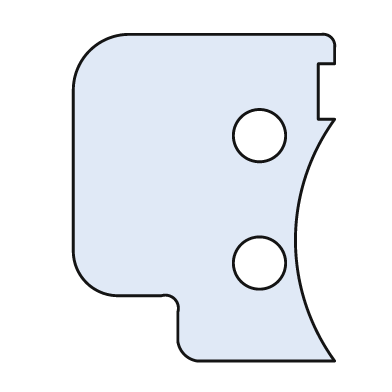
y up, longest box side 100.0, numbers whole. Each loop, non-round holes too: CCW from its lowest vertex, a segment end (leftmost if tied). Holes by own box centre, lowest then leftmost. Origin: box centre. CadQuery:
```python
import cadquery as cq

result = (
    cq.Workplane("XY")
    .moveTo(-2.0, -50.0)
    .lineTo(40.0, -50.0)
    .threePointArc((28.0, -13.0), (40.0, 24.0))
    .lineTo(35.0, 24.0)
    .lineTo(35.0, 41.0)
    .lineTo(40.0, 41.0)
    .lineTo(40.0, 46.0)
    .threePointArc((39.0, 49.0), (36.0, 50.0))
    .lineTo(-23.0, 50.0)
    .threePointArc((-35.0, 45.0), (-40.0, 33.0))
    .lineTo(-40.0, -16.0)
    .threePointArc((-36.0, -26.0), (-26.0, -30.0))
    .lineTo(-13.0, -30.0)
    .threePointArc((-9.0, -31.0), (-8.0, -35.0))
    .lineTo(-8.0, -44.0)
    .threePointArc((-6.0, -48.0), (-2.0, -50.0))
    .close()
    .moveTo(17.0, -20.0)
    .circle(8.0)
    .moveTo(17.0, 19.0)
    .circle(8.0)
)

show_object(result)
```